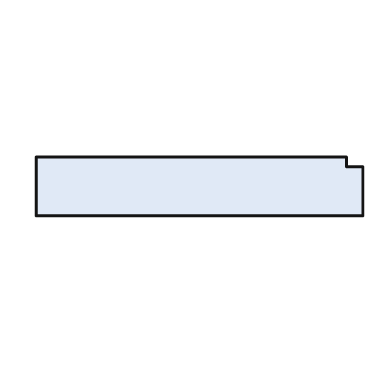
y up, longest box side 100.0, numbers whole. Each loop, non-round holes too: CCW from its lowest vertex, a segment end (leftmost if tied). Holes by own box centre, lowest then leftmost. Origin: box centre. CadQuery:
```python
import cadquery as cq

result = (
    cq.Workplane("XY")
    .moveTo(-50.0, -9.0)
    .lineTo(50.0, -9.0)
    .lineTo(50.0, 6.0)
    .lineTo(45.0, 6.0)
    .lineTo(45.0, 9.0)
    .lineTo(-50.0, 9.0)
    .close()
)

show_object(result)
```